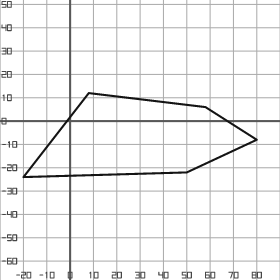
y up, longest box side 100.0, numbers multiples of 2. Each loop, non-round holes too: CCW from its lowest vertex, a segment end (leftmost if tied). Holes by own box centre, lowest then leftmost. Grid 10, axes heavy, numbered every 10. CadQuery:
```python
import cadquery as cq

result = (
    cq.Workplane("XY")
    .moveTo(-20.0, -24.0)
    .lineTo(50.0, -22.0)
    .lineTo(80.0, -8.0)
    .lineTo(58.0, 6.0)
    .lineTo(8.0, 12.0)
    .close()
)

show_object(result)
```